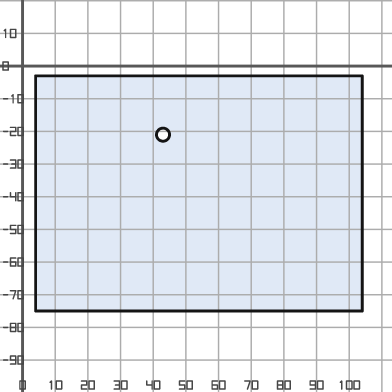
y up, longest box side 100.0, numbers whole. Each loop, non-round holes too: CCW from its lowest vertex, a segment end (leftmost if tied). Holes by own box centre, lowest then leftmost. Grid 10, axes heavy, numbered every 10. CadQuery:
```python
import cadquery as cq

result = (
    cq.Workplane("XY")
    .moveTo(4.0, -75.0)
    .lineTo(104.0, -75.0)
    .lineTo(104.0, -3.0)
    .lineTo(4.0, -3.0)
    .close()
    .moveTo(43.0, -21.0)
    .circle(2.0)
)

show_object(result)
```